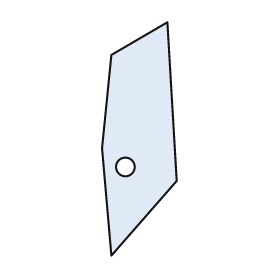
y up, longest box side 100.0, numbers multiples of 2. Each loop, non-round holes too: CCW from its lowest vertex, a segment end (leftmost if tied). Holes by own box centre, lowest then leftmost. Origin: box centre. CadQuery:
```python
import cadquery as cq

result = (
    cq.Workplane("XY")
    .moveTo(-12.0, -50.0)
    .lineTo(16.0, -18.0)
    .lineTo(12.0, 50.0)
    .lineTo(-12.0, 36.0)
    .lineTo(-16.0, -4.0)
    .close()
    .moveTo(-6.0, -12.0)
    .circle(4.0)
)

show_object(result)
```